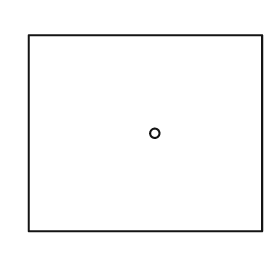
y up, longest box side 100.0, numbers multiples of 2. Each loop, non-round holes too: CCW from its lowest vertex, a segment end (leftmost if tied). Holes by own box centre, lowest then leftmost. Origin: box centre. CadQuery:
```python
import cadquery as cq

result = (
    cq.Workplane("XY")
    .moveTo(-50.0, -42.0)
    .lineTo(50.0, -42.0)
    .lineTo(50.0, 42.0)
    .lineTo(-50.0, 42.0)
    .close()
    .moveTo(4.0, 0.0)
    .circle(2.0)
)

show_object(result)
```